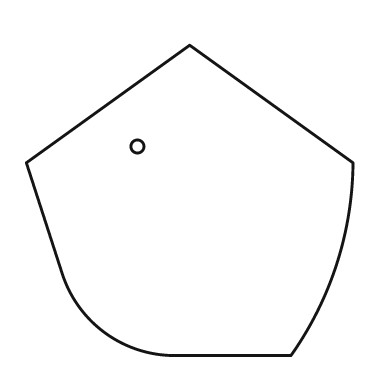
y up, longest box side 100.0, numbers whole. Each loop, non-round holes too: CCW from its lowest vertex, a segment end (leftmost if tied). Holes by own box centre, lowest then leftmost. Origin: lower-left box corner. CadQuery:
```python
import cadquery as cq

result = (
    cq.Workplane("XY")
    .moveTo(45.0, 0.0)
    .lineTo(81.0, 0.0)
    .threePointArc((95.0, 28.0), (100.0, 59.0))
    .lineTo(50.0, 95.0)
    .lineTo(0.0, 59.0)
    .lineTo(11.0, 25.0)
    .threePointArc((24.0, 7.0), (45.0, 0.0))
    .close()
    .moveTo(34.0, 64.0)
    .circle(2.0)
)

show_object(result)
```